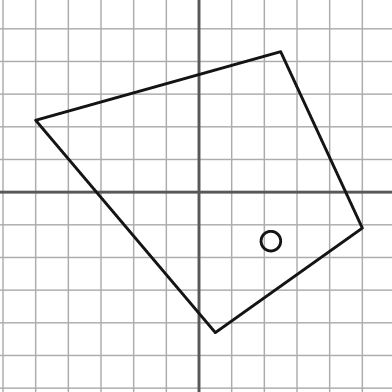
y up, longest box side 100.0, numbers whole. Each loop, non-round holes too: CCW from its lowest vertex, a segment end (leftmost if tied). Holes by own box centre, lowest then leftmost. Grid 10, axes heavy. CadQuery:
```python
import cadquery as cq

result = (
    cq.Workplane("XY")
    .moveTo(5.0, -43.0)
    .lineTo(50.0, -11.0)
    .lineTo(25.0, 43.0)
    .lineTo(-50.0, 22.0)
    .close()
    .moveTo(22.0, -15.0)
    .circle(3.0)
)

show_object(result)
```